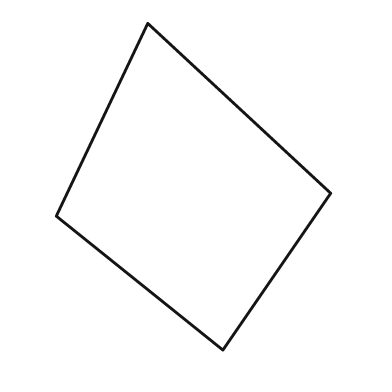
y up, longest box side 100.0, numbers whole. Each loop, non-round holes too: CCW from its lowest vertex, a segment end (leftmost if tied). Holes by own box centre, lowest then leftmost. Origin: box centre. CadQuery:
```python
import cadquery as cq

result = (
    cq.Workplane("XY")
    .moveTo(9.0, -50.0)
    .lineTo(42.0, -2.0)
    .lineTo(-14.0, 50.0)
    .lineTo(-42.0, -9.0)
    .close()
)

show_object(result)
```